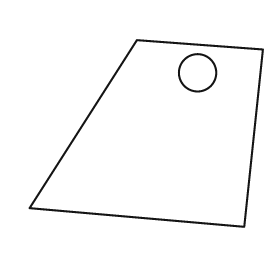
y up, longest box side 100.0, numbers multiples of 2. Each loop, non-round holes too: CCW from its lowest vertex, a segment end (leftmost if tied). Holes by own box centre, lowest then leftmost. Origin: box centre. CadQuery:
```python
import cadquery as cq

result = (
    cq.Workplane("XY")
    .moveTo(42.0, -40.0)
    .lineTo(50.0, 36.0)
    .lineTo(-4.0, 40.0)
    .lineTo(-50.0, -32.0)
    .close()
    .moveTo(22.0, 26.0)
    .circle(8.0)
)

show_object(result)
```